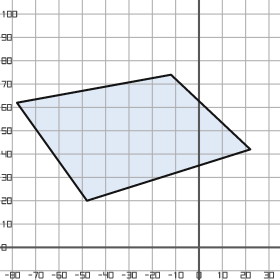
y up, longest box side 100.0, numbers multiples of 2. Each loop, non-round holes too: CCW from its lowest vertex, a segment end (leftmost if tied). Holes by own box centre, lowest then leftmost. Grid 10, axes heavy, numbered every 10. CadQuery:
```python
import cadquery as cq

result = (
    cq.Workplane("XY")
    .moveTo(-48.0, 20.0)
    .lineTo(22.0, 42.0)
    .lineTo(-12.0, 74.0)
    .lineTo(-78.0, 62.0)
    .close()
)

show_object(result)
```